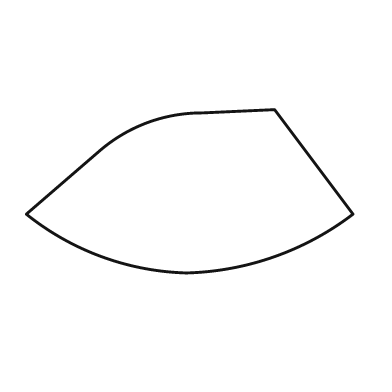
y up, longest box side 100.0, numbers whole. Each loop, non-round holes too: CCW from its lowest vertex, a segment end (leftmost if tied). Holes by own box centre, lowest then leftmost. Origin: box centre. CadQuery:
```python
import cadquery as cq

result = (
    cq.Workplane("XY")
    .moveTo(-1.0, -25.0)
    .threePointArc((26.0, -20.0), (50.0, -7.0))
    .lineTo(26.0, 25.0)
    .lineTo(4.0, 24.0)
    .threePointArc((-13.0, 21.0), (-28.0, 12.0))
    .lineTo(-50.0, -7.0)
    .threePointArc((-27.0, -20.0), (-1.0, -25.0))
    .close()
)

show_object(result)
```